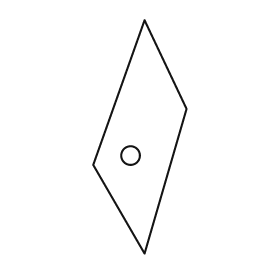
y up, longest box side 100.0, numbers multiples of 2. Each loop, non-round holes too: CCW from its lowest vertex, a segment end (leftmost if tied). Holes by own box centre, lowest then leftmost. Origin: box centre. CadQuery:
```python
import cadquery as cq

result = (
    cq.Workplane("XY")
    .moveTo(2.0, -50.0)
    .lineTo(20.0, 12.0)
    .lineTo(2.0, 50.0)
    .lineTo(-20.0, -12.0)
    .close()
    .moveTo(-4.0, -8.0)
    .circle(4.0)
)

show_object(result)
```